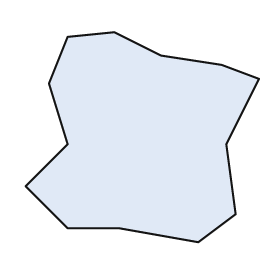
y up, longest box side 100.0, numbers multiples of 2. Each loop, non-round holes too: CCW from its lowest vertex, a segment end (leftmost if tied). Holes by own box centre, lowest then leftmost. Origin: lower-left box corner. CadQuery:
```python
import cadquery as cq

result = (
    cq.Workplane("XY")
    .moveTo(74.0, 0.0)
    .lineTo(90.0, 12.0)
    .lineTo(86.0, 42.0)
    .lineTo(100.0, 70.0)
    .lineTo(84.0, 76.0)
    .lineTo(58.0, 80.0)
    .lineTo(38.0, 90.0)
    .lineTo(18.0, 88.0)
    .lineTo(10.0, 68.0)
    .lineTo(18.0, 42.0)
    .lineTo(0.0, 24.0)
    .lineTo(18.0, 6.0)
    .lineTo(40.0, 6.0)
    .close()
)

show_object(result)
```